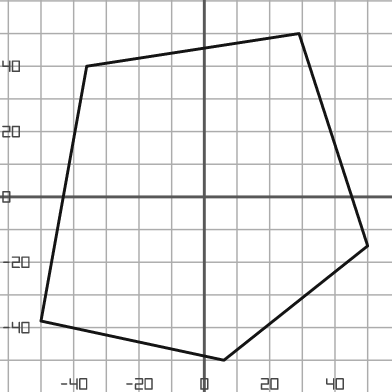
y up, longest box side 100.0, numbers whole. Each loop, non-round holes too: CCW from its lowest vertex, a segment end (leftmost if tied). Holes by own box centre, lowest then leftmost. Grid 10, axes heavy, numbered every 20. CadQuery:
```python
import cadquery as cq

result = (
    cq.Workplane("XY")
    .moveTo(6.0, -50.0)
    .lineTo(50.0, -15.0)
    .lineTo(29.0, 50.0)
    .lineTo(-36.0, 40.0)
    .lineTo(-50.0, -38.0)
    .close()
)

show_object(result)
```